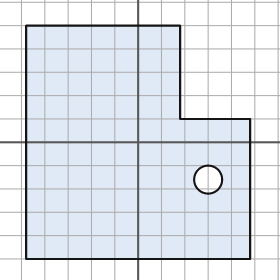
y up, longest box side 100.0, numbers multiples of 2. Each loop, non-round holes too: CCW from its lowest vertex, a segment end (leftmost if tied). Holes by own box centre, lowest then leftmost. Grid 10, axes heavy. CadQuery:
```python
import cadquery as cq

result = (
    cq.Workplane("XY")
    .moveTo(-48.0, -50.0)
    .lineTo(48.0, -50.0)
    .lineTo(48.0, 10.0)
    .lineTo(18.0, 10.0)
    .lineTo(18.0, 50.0)
    .lineTo(-48.0, 50.0)
    .close()
    .moveTo(30.0, -16.0)
    .circle(6.0)
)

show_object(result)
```